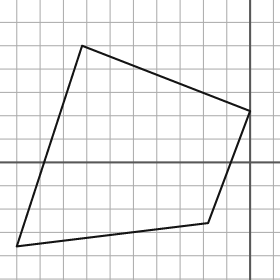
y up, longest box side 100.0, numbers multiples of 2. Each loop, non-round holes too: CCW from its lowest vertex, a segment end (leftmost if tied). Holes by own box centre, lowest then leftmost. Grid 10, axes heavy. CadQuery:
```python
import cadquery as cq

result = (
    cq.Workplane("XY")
    .moveTo(-100.0, -36.0)
    .lineTo(-18.0, -26.0)
    .lineTo(0.0, 22.0)
    .lineTo(-72.0, 50.0)
    .close()
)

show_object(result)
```